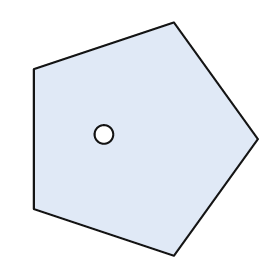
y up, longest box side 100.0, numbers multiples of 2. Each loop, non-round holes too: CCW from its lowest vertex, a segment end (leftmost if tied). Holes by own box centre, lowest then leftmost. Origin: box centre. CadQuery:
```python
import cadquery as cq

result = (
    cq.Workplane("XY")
    .moveTo(12.0, -50.0)
    .lineTo(48.0, 0.0)
    .lineTo(12.0, 50.0)
    .lineTo(-48.0, 30.0)
    .lineTo(-48.0, -30.0)
    .close()
    .moveTo(-18.0, 2.0)
    .circle(4.0)
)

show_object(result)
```